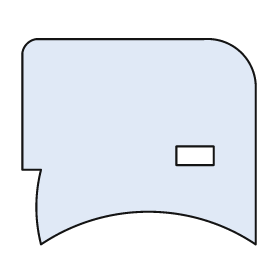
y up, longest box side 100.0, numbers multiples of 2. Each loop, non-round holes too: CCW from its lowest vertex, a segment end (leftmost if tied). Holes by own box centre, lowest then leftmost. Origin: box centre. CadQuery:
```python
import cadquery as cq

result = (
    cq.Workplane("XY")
    .moveTo(-42.0, -44.0)
    .threePointArc((4.0, -30.0), (50.0, -44.0))
    .lineTo(50.0, 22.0)
    .threePointArc((44.0, 38.0), (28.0, 44.0))
    .lineTo(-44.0, 44.0)
    .threePointArc((-48.0, 42.0), (-50.0, 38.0))
    .lineTo(-50.0, -12.0)
    .lineTo(-42.0, -12.0)
    .threePointArc((-44.0, -28.0), (-42.0, -44.0))
    .close()
    .moveTo(16.0, -10.0)
    .lineTo(32.0, -10.0)
    .lineTo(32.0, -2.0)
    .lineTo(16.0, -2.0)
    .close()
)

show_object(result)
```